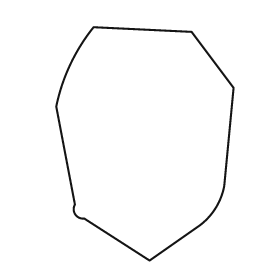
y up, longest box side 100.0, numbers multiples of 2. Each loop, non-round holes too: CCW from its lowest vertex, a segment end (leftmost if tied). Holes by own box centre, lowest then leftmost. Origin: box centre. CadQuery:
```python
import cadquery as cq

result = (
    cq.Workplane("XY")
    .moveTo(2.0, -50.0)
    .lineTo(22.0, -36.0)
    .threePointArc((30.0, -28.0), (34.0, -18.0))
    .lineTo(38.0, 24.0)
    .lineTo(20.0, 48.0)
    .lineTo(-22.0, 50.0)
    .threePointArc((-32.0, 34.0), (-38.0, 16.0))
    .lineTo(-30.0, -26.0)
    .threePointArc((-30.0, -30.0), (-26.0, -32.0))
    .close()
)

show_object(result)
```